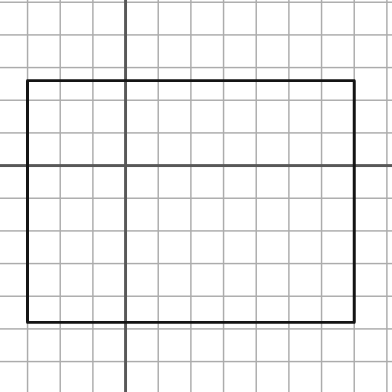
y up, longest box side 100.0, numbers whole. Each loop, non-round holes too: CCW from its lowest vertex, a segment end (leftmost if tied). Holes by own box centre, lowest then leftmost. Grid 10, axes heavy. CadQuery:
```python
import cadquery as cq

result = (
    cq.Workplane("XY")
    .moveTo(-30.0, -48.0)
    .lineTo(70.0, -48.0)
    .lineTo(70.0, 26.0)
    .lineTo(-30.0, 26.0)
    .close()
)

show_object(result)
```